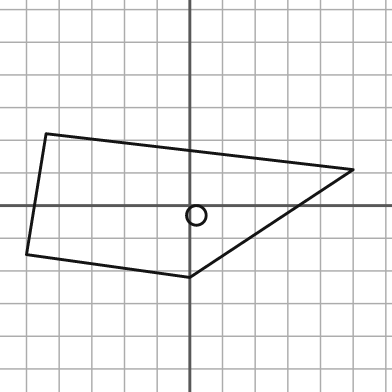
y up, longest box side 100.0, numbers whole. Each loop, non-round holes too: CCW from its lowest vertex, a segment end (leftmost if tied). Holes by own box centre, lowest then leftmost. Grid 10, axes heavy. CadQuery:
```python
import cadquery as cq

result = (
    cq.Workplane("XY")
    .moveTo(0.0, -22.0)
    .lineTo(50.0, 11.0)
    .lineTo(-44.0, 22.0)
    .lineTo(-50.0, -15.0)
    .close()
    .moveTo(2.0, -3.0)
    .circle(3.0)
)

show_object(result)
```